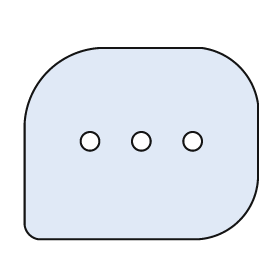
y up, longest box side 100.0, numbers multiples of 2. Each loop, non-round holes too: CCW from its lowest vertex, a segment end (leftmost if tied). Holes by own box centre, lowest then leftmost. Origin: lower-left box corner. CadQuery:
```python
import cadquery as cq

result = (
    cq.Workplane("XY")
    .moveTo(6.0, 0.0)
    .lineTo(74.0, 0.0)
    .threePointArc((92.0, 8.0), (100.0, 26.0))
    .lineTo(100.0, 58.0)
    .threePointArc((92.0, 74.0), (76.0, 82.0))
    .lineTo(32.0, 82.0)
    .threePointArc((10.0, 72.0), (0.0, 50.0))
    .lineTo(0.0, 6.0)
    .threePointArc((2.0, 2.0), (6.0, 0.0))
    .close()
    .moveTo(28.0, 42.0)
    .circle(4.0)
    .moveTo(50.0, 42.0)
    .circle(4.0)
    .moveTo(72.0, 42.0)
    .circle(4.0)
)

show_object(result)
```